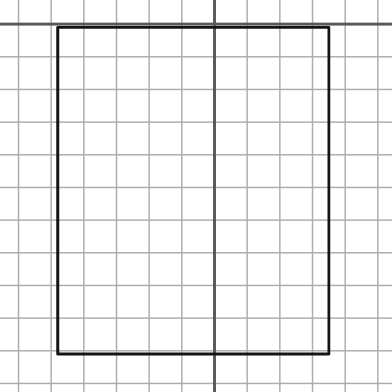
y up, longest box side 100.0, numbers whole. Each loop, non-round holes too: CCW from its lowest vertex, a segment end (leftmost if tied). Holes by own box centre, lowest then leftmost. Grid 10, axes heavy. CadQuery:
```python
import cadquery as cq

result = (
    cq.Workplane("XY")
    .moveTo(-48.0, -101.0)
    .lineTo(35.0, -101.0)
    .lineTo(35.0, -1.0)
    .lineTo(-48.0, -1.0)
    .close()
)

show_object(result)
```